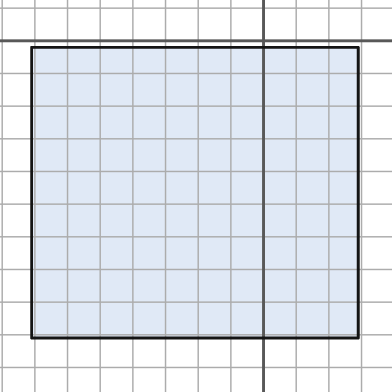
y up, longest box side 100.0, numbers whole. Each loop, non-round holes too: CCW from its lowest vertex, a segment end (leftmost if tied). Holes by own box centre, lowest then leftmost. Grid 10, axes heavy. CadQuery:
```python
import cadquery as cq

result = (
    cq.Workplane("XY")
    .moveTo(-71.0, -91.0)
    .lineTo(29.0, -91.0)
    .lineTo(29.0, -2.0)
    .lineTo(-71.0, -2.0)
    .close()
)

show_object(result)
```